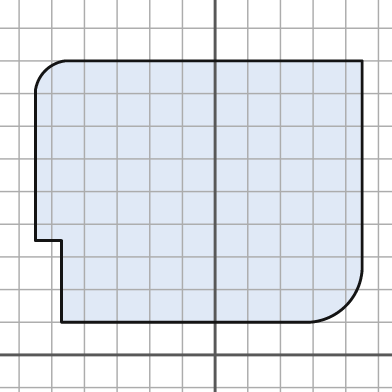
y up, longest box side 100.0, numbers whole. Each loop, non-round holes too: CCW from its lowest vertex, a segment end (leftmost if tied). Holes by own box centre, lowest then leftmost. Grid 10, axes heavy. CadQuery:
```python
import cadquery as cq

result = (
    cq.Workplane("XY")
    .moveTo(-47.0, 10.0)
    .lineTo(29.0, 10.0)
    .threePointArc((40.0, 15.0), (45.0, 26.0))
    .lineTo(45.0, 90.0)
    .lineTo(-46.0, 90.0)
    .threePointArc((-52.0, 87.0), (-55.0, 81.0))
    .lineTo(-55.0, 35.0)
    .lineTo(-47.0, 35.0)
    .close()
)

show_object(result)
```